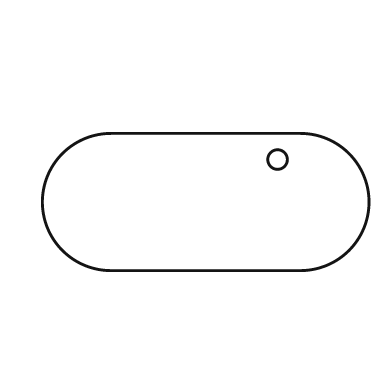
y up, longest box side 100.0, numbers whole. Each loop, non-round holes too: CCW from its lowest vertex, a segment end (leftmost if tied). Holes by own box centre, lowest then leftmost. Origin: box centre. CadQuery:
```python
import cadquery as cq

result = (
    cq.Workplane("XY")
    .moveTo(-29.0, -21.0)
    .lineTo(29.0, -21.0)
    .threePointArc((50.0, 0.0), (29.0, 21.0))
    .lineTo(-29.0, 21.0)
    .threePointArc((-50.0, 0.0), (-29.0, -21.0))
    .close()
    .moveTo(22.0, 13.0)
    .circle(3.0)
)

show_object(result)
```